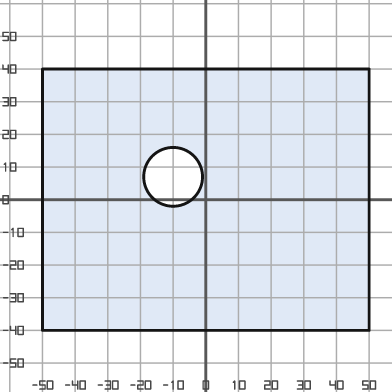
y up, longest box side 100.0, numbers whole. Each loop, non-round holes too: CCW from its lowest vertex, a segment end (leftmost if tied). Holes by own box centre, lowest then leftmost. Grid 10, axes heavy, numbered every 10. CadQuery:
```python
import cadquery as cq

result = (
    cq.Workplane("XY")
    .moveTo(-50.0, -40.0)
    .lineTo(50.0, -40.0)
    .lineTo(50.0, 40.0)
    .lineTo(-50.0, 40.0)
    .close()
    .moveTo(-10.0, 7.0)
    .circle(9.0)
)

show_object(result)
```